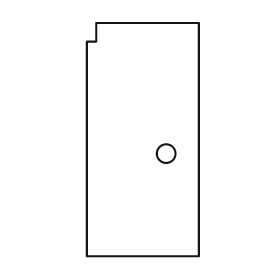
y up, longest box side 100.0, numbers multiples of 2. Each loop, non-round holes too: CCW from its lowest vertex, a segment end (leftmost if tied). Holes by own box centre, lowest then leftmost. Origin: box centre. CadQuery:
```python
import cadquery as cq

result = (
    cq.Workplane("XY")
    .moveTo(-24.0, -50.0)
    .lineTo(24.0, -50.0)
    .lineTo(24.0, 50.0)
    .lineTo(-20.0, 50.0)
    .lineTo(-20.0, 42.0)
    .lineTo(-24.0, 42.0)
    .close()
    .moveTo(10.0, -6.0)
    .circle(4.0)
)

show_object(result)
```